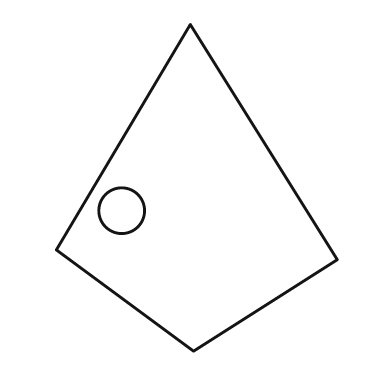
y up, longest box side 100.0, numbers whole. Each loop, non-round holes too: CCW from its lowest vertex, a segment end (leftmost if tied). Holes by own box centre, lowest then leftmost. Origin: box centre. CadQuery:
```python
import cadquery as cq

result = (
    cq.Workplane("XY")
    .moveTo(-1.0, -50.0)
    .lineTo(43.0, -22.0)
    .lineTo(-2.0, 50.0)
    .lineTo(-43.0, -19.0)
    .close()
    .moveTo(-23.0, -7.0)
    .circle(7.0)
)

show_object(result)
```